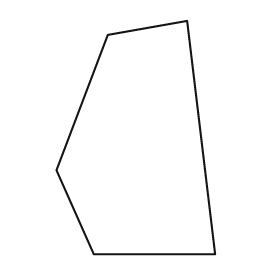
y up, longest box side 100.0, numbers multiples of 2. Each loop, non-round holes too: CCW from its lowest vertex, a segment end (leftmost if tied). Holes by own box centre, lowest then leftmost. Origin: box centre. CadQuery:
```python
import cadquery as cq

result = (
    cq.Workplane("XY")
    .moveTo(-18.0, -50.0)
    .lineTo(34.0, -50.0)
    .lineTo(22.0, 50.0)
    .lineTo(-12.0, 44.0)
    .lineTo(-34.0, -14.0)
    .close()
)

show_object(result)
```